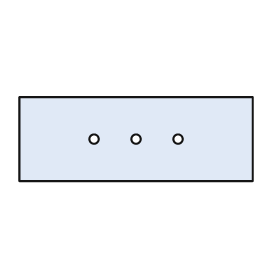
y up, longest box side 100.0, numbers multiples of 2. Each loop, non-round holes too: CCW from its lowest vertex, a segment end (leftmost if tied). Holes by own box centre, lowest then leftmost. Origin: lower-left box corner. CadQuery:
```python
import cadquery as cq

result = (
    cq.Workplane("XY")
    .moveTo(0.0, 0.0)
    .lineTo(100.0, 0.0)
    .lineTo(100.0, 36.0)
    .lineTo(0.0, 36.0)
    .close()
    .moveTo(32.0, 18.0)
    .circle(2.0)
    .moveTo(50.0, 18.0)
    .circle(2.0)
    .moveTo(68.0, 18.0)
    .circle(2.0)
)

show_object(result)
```